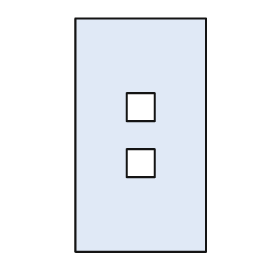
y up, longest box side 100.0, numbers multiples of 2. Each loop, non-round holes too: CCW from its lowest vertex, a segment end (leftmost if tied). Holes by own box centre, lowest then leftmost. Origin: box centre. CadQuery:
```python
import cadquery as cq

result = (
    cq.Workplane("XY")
    .moveTo(-28.0, -50.0)
    .lineTo(28.0, -50.0)
    .lineTo(28.0, 50.0)
    .lineTo(-28.0, 50.0)
    .close()
    .moveTo(-6.0, -18.0)
    .lineTo(6.0, -18.0)
    .lineTo(6.0, -6.0)
    .lineTo(-6.0, -6.0)
    .close()
    .moveTo(-6.0, 6.0)
    .lineTo(6.0, 6.0)
    .lineTo(6.0, 18.0)
    .lineTo(-6.0, 18.0)
    .close()
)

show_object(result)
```